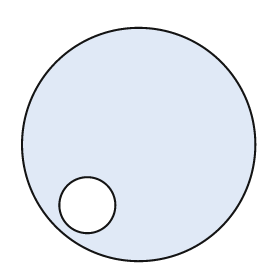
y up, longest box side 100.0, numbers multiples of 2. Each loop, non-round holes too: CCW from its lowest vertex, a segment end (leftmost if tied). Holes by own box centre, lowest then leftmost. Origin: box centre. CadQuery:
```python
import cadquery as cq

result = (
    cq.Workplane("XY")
    .moveTo(0.0, 0.0)
    .circle(50.0)
    .moveTo(-22.0, -26.0)
    .circle(12.0)
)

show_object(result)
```